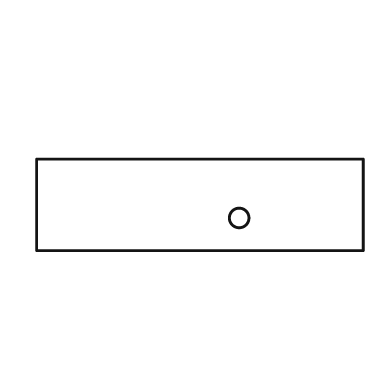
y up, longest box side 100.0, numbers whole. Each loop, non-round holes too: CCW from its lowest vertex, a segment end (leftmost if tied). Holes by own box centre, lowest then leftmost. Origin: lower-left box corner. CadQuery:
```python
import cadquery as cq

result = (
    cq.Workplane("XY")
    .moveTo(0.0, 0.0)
    .lineTo(100.0, 0.0)
    .lineTo(100.0, 28.0)
    .lineTo(0.0, 28.0)
    .close()
    .moveTo(62.0, 10.0)
    .circle(3.0)
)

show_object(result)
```